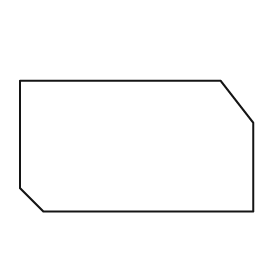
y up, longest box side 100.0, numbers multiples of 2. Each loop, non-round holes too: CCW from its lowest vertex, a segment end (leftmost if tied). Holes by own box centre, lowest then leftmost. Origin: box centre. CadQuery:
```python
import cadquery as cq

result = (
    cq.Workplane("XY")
    .moveTo(-40.0, -28.0)
    .lineTo(50.0, -28.0)
    .lineTo(50.0, 10.0)
    .lineTo(36.0, 28.0)
    .lineTo(-50.0, 28.0)
    .lineTo(-50.0, -18.0)
    .close()
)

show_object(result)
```